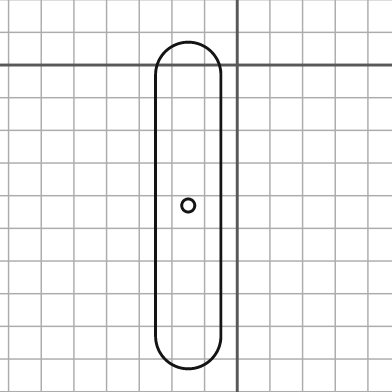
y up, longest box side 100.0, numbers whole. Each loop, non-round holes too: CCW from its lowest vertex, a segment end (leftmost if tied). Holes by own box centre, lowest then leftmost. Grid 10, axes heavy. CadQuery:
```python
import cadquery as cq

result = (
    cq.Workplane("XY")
    .moveTo(-25.0, -83.0)
    .threePointArc((-15.0, -93.0), (-5.0, -83.0))
    .lineTo(-5.0, -3.0)
    .threePointArc((-15.0, 7.0), (-25.0, -3.0))
    .close()
    .moveTo(-15.0, -43.0)
    .circle(2.0)
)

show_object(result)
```